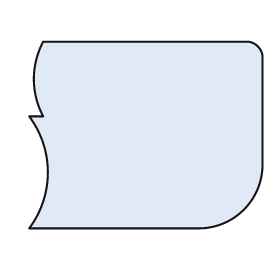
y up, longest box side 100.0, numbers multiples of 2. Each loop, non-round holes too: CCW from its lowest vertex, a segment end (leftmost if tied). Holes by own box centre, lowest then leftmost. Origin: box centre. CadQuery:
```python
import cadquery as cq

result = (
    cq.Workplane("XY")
    .moveTo(-50.0, -40.0)
    .lineTo(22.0, -40.0)
    .threePointArc((42.0, -32.0), (50.0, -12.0))
    .lineTo(50.0, 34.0)
    .threePointArc((48.0, 38.0), (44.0, 40.0))
    .lineTo(-44.0, 40.0)
    .threePointArc((-48.0, 24.0), (-44.0, 8.0))
    .lineTo(-50.0, 8.0)
    .threePointArc((-42.0, -16.0), (-50.0, -40.0))
    .close()
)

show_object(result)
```